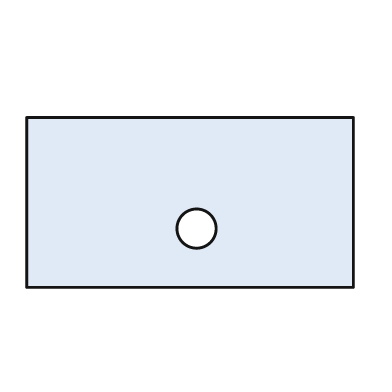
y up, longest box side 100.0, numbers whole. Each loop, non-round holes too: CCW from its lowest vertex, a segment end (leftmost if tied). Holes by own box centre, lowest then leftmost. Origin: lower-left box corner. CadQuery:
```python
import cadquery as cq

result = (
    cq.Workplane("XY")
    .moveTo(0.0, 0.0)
    .lineTo(100.0, 0.0)
    .lineTo(100.0, 52.0)
    .lineTo(0.0, 52.0)
    .close()
    .moveTo(52.0, 18.0)
    .circle(6.0)
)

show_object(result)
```